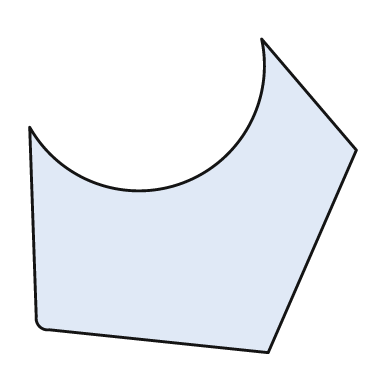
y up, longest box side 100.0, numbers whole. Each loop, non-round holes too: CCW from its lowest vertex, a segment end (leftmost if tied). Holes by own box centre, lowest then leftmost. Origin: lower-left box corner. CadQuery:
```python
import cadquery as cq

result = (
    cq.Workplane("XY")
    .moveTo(73.0, 0.0)
    .lineTo(100.0, 62.0)
    .lineTo(71.0, 96.0)
    .threePointArc((47.0, 52.0), (0.0, 69.0))
    .lineTo(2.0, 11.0)
    .threePointArc((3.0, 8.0), (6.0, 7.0))
    .close()
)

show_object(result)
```